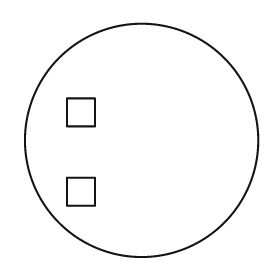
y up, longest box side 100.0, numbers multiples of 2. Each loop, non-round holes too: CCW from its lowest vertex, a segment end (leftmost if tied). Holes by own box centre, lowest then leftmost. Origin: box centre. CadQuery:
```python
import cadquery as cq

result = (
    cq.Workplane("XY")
    .moveTo(0.0, 0.0)
    .circle(50.0)
    .moveTo(-32.0, -28.0)
    .lineTo(-20.0, -28.0)
    .lineTo(-20.0, -16.0)
    .lineTo(-32.0, -16.0)
    .close()
    .moveTo(-32.0, 6.0)
    .lineTo(-20.0, 6.0)
    .lineTo(-20.0, 18.0)
    .lineTo(-32.0, 18.0)
    .close()
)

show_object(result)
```